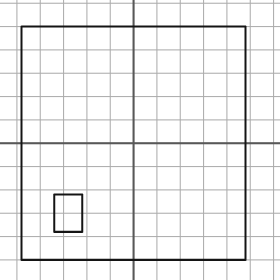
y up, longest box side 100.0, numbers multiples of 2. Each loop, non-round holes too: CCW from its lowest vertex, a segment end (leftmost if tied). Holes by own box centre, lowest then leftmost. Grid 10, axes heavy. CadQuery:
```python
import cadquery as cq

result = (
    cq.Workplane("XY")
    .moveTo(-48.0, -50.0)
    .lineTo(48.0, -50.0)
    .lineTo(48.0, 50.0)
    .lineTo(-48.0, 50.0)
    .close()
    .moveTo(-34.0, -38.0)
    .lineTo(-22.0, -38.0)
    .lineTo(-22.0, -22.0)
    .lineTo(-34.0, -22.0)
    .close()
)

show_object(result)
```